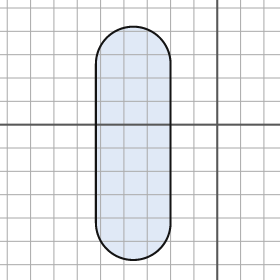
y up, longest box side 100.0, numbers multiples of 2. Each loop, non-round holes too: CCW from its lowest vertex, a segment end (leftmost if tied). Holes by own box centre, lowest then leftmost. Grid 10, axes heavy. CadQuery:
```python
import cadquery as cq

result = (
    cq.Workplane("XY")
    .moveTo(-52.0, -42.0)
    .threePointArc((-36.0, -58.0), (-20.0, -42.0))
    .lineTo(-20.0, 26.0)
    .threePointArc((-36.0, 42.0), (-52.0, 26.0))
    .close()
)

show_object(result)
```